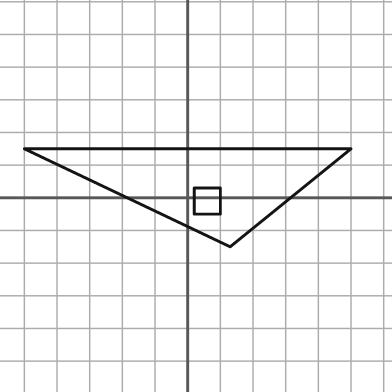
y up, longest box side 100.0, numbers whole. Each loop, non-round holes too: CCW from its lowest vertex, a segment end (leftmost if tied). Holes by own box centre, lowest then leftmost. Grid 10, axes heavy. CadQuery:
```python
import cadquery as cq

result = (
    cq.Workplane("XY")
    .moveTo(13.0, -15.0)
    .lineTo(50.0, 15.0)
    .lineTo(-50.0, 15.0)
    .close()
    .moveTo(2.0, -5.0)
    .lineTo(10.0, -5.0)
    .lineTo(10.0, 3.0)
    .lineTo(2.0, 3.0)
    .close()
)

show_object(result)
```